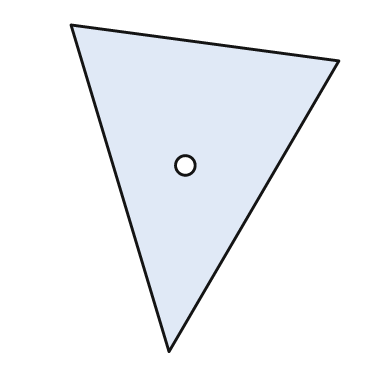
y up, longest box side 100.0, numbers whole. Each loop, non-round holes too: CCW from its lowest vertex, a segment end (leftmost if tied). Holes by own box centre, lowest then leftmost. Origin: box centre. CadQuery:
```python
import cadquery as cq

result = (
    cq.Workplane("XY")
    .moveTo(-11.0, -50.0)
    .lineTo(41.0, 39.0)
    .lineTo(-41.0, 50.0)
    .close()
    .moveTo(-6.0, 7.0)
    .circle(3.0)
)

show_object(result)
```